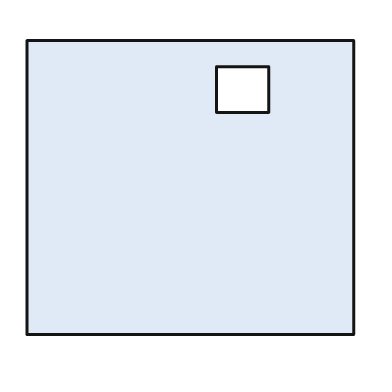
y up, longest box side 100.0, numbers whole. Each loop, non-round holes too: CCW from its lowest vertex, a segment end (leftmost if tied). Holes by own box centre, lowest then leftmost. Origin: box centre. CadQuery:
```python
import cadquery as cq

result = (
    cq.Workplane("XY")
    .moveTo(-50.0, -45.0)
    .lineTo(50.0, -45.0)
    .lineTo(50.0, 45.0)
    .lineTo(-50.0, 45.0)
    .close()
    .moveTo(8.0, 23.0)
    .lineTo(24.0, 23.0)
    .lineTo(24.0, 37.0)
    .lineTo(8.0, 37.0)
    .close()
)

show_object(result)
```